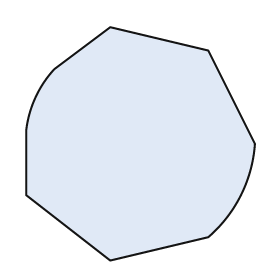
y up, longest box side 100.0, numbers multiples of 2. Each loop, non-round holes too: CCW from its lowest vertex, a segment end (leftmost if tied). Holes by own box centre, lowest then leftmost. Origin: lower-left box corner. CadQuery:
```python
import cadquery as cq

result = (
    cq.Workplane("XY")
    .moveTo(36.0, 0.0)
    .lineTo(78.0, 10.0)
    .threePointArc((92.0, 28.0), (98.0, 50.0))
    .lineTo(78.0, 90.0)
    .lineTo(36.0, 100.0)
    .lineTo(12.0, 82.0)
    .threePointArc((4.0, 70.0), (0.0, 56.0))
    .lineTo(0.0, 28.0)
    .close()
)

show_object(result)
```